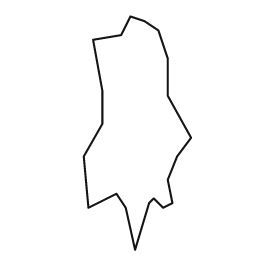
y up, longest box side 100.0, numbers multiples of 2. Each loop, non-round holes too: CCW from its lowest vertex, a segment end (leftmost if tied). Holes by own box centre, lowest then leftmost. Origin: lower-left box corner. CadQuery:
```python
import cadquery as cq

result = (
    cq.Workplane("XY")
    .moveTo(22.0, 0.0)
    .lineTo(28.0, 20.0)
    .lineTo(30.0, 22.0)
    .lineTo(34.0, 18.0)
    .lineTo(38.0, 20.0)
    .lineTo(36.0, 30.0)
    .lineTo(40.0, 40.0)
    .lineTo(46.0, 48.0)
    .lineTo(36.0, 66.0)
    .lineTo(36.0, 82.0)
    .lineTo(32.0, 94.0)
    .lineTo(26.0, 98.0)
    .lineTo(20.0, 100.0)
    .lineTo(16.0, 92.0)
    .lineTo(4.0, 90.0)
    .lineTo(8.0, 68.0)
    .lineTo(8.0, 54.0)
    .lineTo(0.0, 40.0)
    .lineTo(2.0, 18.0)
    .lineTo(14.0, 24.0)
    .lineTo(18.0, 18.0)
    .close()
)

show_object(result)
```